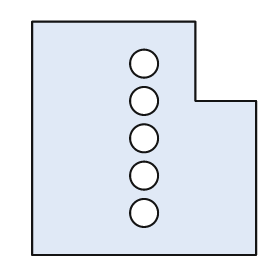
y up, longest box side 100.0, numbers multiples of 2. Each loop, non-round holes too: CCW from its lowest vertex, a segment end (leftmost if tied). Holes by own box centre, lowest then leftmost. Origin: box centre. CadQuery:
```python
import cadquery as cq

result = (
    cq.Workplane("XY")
    .moveTo(-48.0, -50.0)
    .lineTo(48.0, -50.0)
    .lineTo(48.0, 16.0)
    .lineTo(22.0, 16.0)
    .lineTo(22.0, 50.0)
    .lineTo(-48.0, 50.0)
    .close()
    .moveTo(0.0, -32.0)
    .circle(6.0)
    .moveTo(0.0, -16.0)
    .circle(6.0)
    .moveTo(0.0, 0.0)
    .circle(6.0)
    .moveTo(0.0, 16.0)
    .circle(6.0)
    .moveTo(0.0, 32.0)
    .circle(6.0)
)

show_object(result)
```